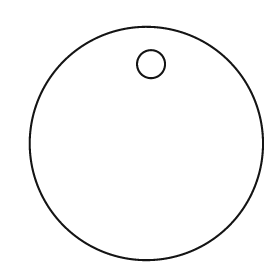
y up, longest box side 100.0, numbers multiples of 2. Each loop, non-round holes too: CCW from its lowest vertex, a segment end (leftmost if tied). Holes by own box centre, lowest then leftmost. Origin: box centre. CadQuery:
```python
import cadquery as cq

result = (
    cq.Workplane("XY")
    .moveTo(0.0, 0.0)
    .circle(50.0)
    .moveTo(2.0, 34.0)
    .circle(6.0)
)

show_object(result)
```